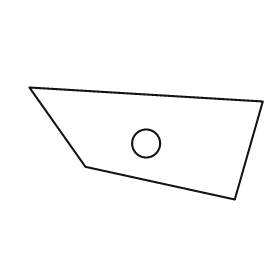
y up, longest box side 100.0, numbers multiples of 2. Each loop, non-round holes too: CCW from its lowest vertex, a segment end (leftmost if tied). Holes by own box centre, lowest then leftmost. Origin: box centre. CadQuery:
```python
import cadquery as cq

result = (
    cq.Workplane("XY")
    .moveTo(38.0, -24.0)
    .lineTo(50.0, 18.0)
    .lineTo(-50.0, 24.0)
    .lineTo(-26.0, -10.0)
    .close()
    .moveTo(0.0, 0.0)
    .circle(6.0)
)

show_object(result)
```